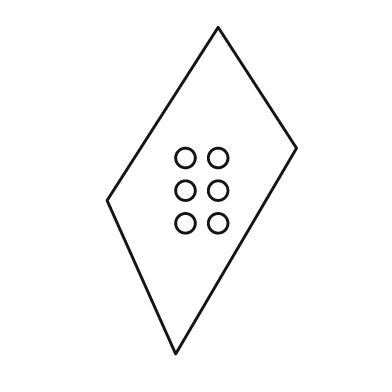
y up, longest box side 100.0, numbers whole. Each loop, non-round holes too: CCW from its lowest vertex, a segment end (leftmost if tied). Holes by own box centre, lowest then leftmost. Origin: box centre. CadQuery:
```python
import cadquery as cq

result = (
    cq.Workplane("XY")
    .moveTo(-8.0, -50.0)
    .lineTo(29.0, 13.0)
    .lineTo(5.0, 50.0)
    .lineTo(-29.0, -3.0)
    .close()
    .moveTo(-5.0, -10.0)
    .circle(3.0)
    .moveTo(5.0, -10.0)
    .circle(3.0)
    .moveTo(-5.0, 0.0)
    .circle(3.0)
    .moveTo(5.0, 0.0)
    .circle(3.0)
    .moveTo(-5.0, 10.0)
    .circle(3.0)
    .moveTo(5.0, 10.0)
    .circle(3.0)
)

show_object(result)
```